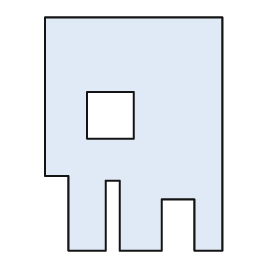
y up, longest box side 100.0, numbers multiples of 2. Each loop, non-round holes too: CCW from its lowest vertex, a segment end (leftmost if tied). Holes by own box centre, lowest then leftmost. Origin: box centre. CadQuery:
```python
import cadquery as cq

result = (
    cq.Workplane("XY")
    .moveTo(-28.0, -50.0)
    .lineTo(-12.0, -50.0)
    .lineTo(-12.0, -20.0)
    .lineTo(-6.0, -20.0)
    .lineTo(-6.0, -50.0)
    .lineTo(12.0, -50.0)
    .lineTo(12.0, -28.0)
    .lineTo(26.0, -28.0)
    .lineTo(26.0, -50.0)
    .lineTo(38.0, -50.0)
    .lineTo(38.0, 50.0)
    .lineTo(-38.0, 50.0)
    .lineTo(-38.0, -18.0)
    .lineTo(-28.0, -18.0)
    .close()
    .moveTo(-20.0, -2.0)
    .lineTo(0.0, -2.0)
    .lineTo(0.0, 18.0)
    .lineTo(-20.0, 18.0)
    .close()
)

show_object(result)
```